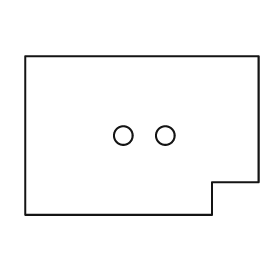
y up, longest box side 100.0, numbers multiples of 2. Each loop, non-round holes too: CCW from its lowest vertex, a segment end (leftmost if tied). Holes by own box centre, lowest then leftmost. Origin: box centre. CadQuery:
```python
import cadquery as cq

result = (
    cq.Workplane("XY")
    .moveTo(-50.0, -34.0)
    .lineTo(30.0, -34.0)
    .lineTo(30.0, -20.0)
    .lineTo(50.0, -20.0)
    .lineTo(50.0, 34.0)
    .lineTo(-50.0, 34.0)
    .close()
    .moveTo(-8.0, 0.0)
    .circle(4.0)
    .moveTo(10.0, 0.0)
    .circle(4.0)
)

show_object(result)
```